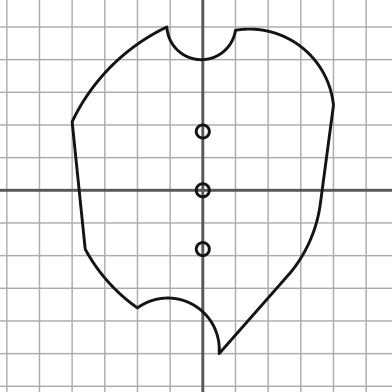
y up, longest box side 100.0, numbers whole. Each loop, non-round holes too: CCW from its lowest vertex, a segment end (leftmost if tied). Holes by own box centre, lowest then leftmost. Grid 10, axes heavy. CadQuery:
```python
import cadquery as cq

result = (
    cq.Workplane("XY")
    .moveTo(5.0, -50.0)
    .lineTo(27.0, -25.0)
    .threePointArc((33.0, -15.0), (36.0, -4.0))
    .lineTo(40.0, 26.0)
    .threePointArc((30.0, 44.0), (10.0, 49.0))
    .threePointArc((-1.0, 40.0), (-11.0, 50.0))
    .threePointArc((-28.0, 38.0), (-40.0, 21.0))
    .lineTo(-36.0, -18.0)
    .threePointArc((-29.0, -28.0), (-20.0, -36.0))
    .threePointArc((-3.0, -35.0), (5.0, -50.0))
    .close()
    .moveTo(0.0, -18.0)
    .circle(2.0)
    .moveTo(0.0, 0.0)
    .circle(2.0)
    .moveTo(0.0, 18.0)
    .circle(2.0)
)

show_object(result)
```